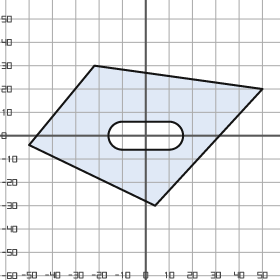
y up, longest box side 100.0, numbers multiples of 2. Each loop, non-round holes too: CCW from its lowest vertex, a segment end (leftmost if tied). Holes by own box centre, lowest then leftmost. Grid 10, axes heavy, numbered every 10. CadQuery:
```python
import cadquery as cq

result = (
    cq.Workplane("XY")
    .moveTo(4.0, -30.0)
    .lineTo(50.0, 20.0)
    .lineTo(-22.0, 30.0)
    .lineTo(-50.0, -4.0)
    .close()
    .moveTo(-10.0, -6.0)
    .lineTo(10.0, -6.0)
    .threePointArc((16.0, 0.0), (10.0, 6.0))
    .lineTo(-10.0, 6.0)
    .threePointArc((-16.0, 0.0), (-10.0, -6.0))
    .close()
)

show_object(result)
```